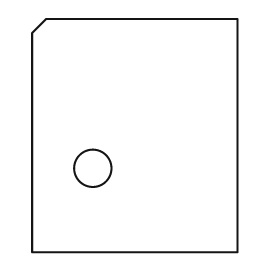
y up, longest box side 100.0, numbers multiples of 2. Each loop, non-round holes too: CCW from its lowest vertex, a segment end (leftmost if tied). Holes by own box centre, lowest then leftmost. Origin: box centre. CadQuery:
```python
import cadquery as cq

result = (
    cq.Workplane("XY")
    .moveTo(-44.0, -50.0)
    .lineTo(44.0, -50.0)
    .lineTo(44.0, 50.0)
    .lineTo(-38.0, 50.0)
    .lineTo(-44.0, 44.0)
    .close()
    .moveTo(-18.0, -14.0)
    .circle(8.0)
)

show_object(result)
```